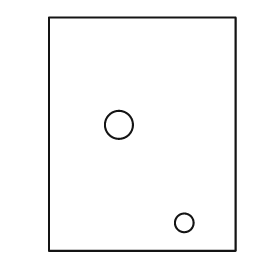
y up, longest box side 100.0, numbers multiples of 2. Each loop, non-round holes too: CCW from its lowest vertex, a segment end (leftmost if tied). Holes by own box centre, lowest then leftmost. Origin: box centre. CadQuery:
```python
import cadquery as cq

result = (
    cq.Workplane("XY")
    .moveTo(-40.0, -50.0)
    .lineTo(40.0, -50.0)
    .lineTo(40.0, 50.0)
    .lineTo(-40.0, 50.0)
    .close()
    .moveTo(18.0, -38.0)
    .circle(4.0)
    .moveTo(-10.0, 4.0)
    .circle(6.0)
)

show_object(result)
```